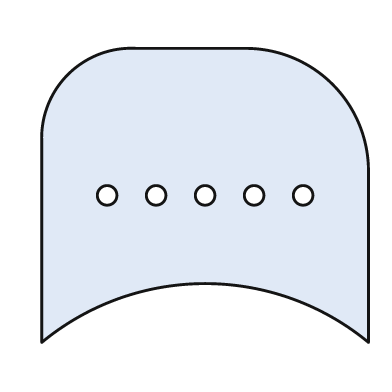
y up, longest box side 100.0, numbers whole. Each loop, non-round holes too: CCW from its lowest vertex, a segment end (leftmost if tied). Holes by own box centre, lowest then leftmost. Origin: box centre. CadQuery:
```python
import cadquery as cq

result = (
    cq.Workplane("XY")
    .moveTo(-50.0, -45.0)
    .threePointArc((0.0, -27.0), (50.0, -45.0))
    .lineTo(50.0, 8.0)
    .threePointArc((39.0, 34.0), (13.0, 45.0))
    .lineTo(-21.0, 45.0)
    .threePointArc((-42.0, 37.0), (-50.0, 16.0))
    .close()
    .moveTo(-30.0, 0.0)
    .circle(3.0)
    .moveTo(-15.0, 0.0)
    .circle(3.0)
    .moveTo(0.0, 0.0)
    .circle(3.0)
    .moveTo(15.0, 0.0)
    .circle(3.0)
    .moveTo(30.0, 0.0)
    .circle(3.0)
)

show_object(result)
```